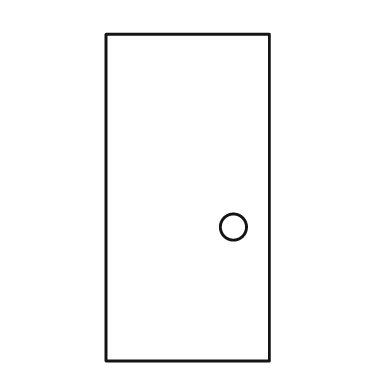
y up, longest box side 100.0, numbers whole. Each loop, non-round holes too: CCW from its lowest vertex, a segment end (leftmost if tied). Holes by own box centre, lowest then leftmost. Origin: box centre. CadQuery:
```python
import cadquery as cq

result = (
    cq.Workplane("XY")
    .moveTo(-25.0, -50.0)
    .lineTo(25.0, -50.0)
    .lineTo(25.0, 50.0)
    .lineTo(-25.0, 50.0)
    .close()
    .moveTo(14.0, -9.0)
    .circle(4.0)
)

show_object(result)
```